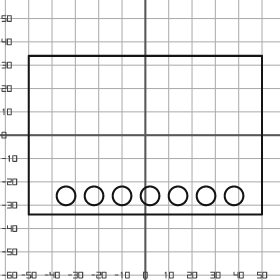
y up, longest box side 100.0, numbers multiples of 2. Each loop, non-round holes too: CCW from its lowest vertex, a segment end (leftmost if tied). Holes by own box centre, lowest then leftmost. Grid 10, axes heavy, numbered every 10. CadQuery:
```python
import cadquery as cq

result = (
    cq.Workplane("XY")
    .moveTo(-50.0, -34.0)
    .lineTo(50.0, -34.0)
    .lineTo(50.0, 34.0)
    .lineTo(-50.0, 34.0)
    .close()
    .moveTo(-34.0, -26.0)
    .circle(4.0)
    .moveTo(-22.0, -26.0)
    .circle(4.0)
    .moveTo(-10.0, -26.0)
    .circle(4.0)
    .moveTo(2.0, -26.0)
    .circle(4.0)
    .moveTo(14.0, -26.0)
    .circle(4.0)
    .moveTo(26.0, -26.0)
    .circle(4.0)
    .moveTo(38.0, -26.0)
    .circle(4.0)
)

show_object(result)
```